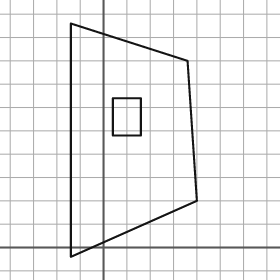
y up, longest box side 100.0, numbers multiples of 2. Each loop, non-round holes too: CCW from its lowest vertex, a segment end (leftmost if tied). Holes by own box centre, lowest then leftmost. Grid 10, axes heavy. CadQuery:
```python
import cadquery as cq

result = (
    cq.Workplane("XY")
    .moveTo(-14.0, -4.0)
    .lineTo(40.0, 20.0)
    .lineTo(36.0, 80.0)
    .lineTo(-14.0, 96.0)
    .close()
    .moveTo(4.0, 48.0)
    .lineTo(16.0, 48.0)
    .lineTo(16.0, 64.0)
    .lineTo(4.0, 64.0)
    .close()
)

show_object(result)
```